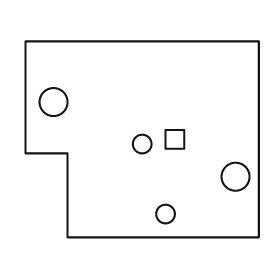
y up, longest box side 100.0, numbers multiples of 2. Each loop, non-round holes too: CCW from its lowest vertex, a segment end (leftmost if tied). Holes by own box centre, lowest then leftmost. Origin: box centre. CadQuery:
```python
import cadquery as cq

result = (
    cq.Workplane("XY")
    .moveTo(-32.0, -42.0)
    .lineTo(50.0, -42.0)
    .lineTo(50.0, 42.0)
    .lineTo(-50.0, 42.0)
    .lineTo(-50.0, -6.0)
    .lineTo(-32.0, -6.0)
    .close()
    .moveTo(10.0, -32.0)
    .circle(4.0)
    .moveTo(40.0, -16.0)
    .circle(6.0)
    .moveTo(0.0, -2.0)
    .circle(4.0)
    .moveTo(10.0, -4.0)
    .lineTo(18.0, -4.0)
    .lineTo(18.0, 4.0)
    .lineTo(10.0, 4.0)
    .close()
    .moveTo(-38.0, 16.0)
    .circle(6.0)
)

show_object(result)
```